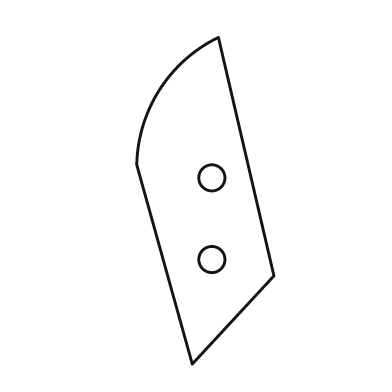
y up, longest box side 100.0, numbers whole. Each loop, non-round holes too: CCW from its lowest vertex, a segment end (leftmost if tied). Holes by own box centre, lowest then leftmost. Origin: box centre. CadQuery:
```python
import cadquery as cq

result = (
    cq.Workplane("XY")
    .moveTo(-4.0, -50.0)
    .lineTo(21.0, -23.0)
    .lineTo(4.0, 50.0)
    .threePointArc((-14.0, 34.0), (-21.0, 11.0))
    .close()
    .moveTo(2.0, -18.0)
    .circle(4.0)
    .moveTo(2.0, 7.0)
    .circle(4.0)
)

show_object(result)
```